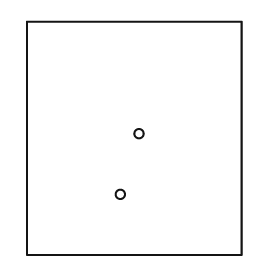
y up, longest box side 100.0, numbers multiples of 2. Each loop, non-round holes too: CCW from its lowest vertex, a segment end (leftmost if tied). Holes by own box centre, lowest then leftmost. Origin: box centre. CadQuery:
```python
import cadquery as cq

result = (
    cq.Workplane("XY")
    .moveTo(-46.0, -50.0)
    .lineTo(46.0, -50.0)
    .lineTo(46.0, 50.0)
    .lineTo(-46.0, 50.0)
    .close()
    .moveTo(-6.0, -24.0)
    .circle(2.0)
    .moveTo(2.0, 2.0)
    .circle(2.0)
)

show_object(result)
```